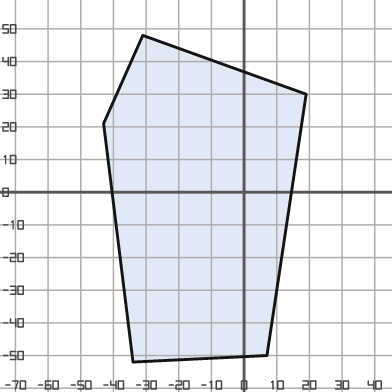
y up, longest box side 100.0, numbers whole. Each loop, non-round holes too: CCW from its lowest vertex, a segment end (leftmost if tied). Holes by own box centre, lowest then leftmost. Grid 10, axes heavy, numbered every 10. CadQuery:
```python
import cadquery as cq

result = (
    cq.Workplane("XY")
    .moveTo(-34.0, -52.0)
    .lineTo(7.0, -50.0)
    .lineTo(19.0, 30.0)
    .lineTo(-31.0, 48.0)
    .lineTo(-43.0, 21.0)
    .close()
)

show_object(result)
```